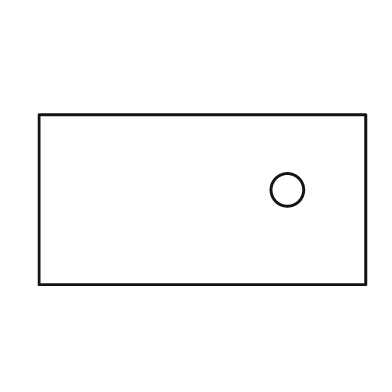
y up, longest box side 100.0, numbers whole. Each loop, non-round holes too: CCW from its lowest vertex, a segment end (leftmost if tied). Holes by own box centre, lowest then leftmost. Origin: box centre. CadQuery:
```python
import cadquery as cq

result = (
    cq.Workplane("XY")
    .moveTo(-50.0, -26.0)
    .lineTo(50.0, -26.0)
    .lineTo(50.0, 26.0)
    .lineTo(-50.0, 26.0)
    .close()
    .moveTo(26.0, 3.0)
    .circle(5.0)
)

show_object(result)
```